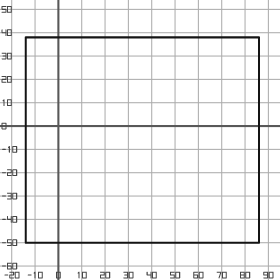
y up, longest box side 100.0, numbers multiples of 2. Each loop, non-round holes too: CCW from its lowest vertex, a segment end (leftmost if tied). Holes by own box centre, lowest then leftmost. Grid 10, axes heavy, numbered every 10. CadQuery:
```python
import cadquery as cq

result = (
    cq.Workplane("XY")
    .moveTo(-14.0, -50.0)
    .lineTo(86.0, -50.0)
    .lineTo(86.0, 38.0)
    .lineTo(-14.0, 38.0)
    .close()
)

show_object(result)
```